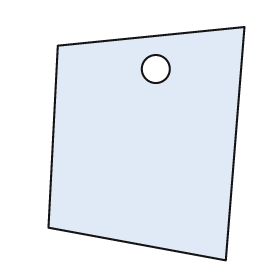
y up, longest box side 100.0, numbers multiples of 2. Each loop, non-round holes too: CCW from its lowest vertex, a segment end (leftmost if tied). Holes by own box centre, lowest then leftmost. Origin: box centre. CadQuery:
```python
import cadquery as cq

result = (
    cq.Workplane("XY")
    .moveTo(34.0, -50.0)
    .lineTo(42.0, 50.0)
    .lineTo(-38.0, 42.0)
    .lineTo(-42.0, -36.0)
    .close()
    .moveTo(4.0, 32.0)
    .circle(6.0)
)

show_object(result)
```